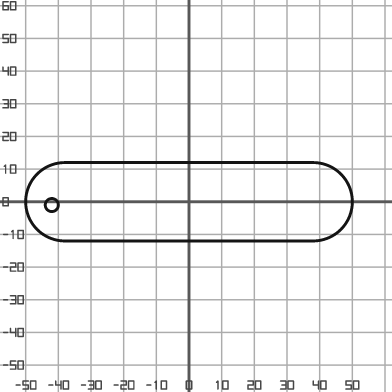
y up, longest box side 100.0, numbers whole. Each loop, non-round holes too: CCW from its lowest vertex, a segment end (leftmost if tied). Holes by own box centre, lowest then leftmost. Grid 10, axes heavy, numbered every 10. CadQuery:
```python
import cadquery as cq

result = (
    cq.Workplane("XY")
    .moveTo(-38.0, -12.0)
    .lineTo(38.0, -12.0)
    .threePointArc((50.0, 0.0), (38.0, 12.0))
    .lineTo(-38.0, 12.0)
    .threePointArc((-50.0, 0.0), (-38.0, -12.0))
    .close()
    .moveTo(-42.0, -1.0)
    .circle(2.0)
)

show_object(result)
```